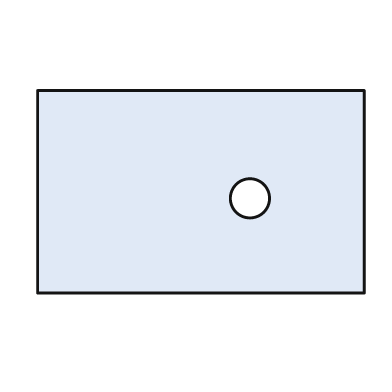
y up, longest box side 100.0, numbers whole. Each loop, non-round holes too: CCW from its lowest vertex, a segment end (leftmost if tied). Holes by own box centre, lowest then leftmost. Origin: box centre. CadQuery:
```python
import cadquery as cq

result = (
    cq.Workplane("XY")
    .moveTo(-50.0, -31.0)
    .lineTo(50.0, -31.0)
    .lineTo(50.0, 31.0)
    .lineTo(-50.0, 31.0)
    .close()
    .moveTo(15.0, -2.0)
    .circle(6.0)
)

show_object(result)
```